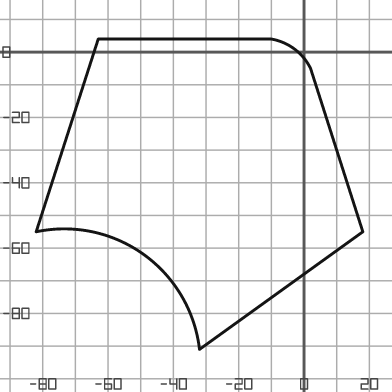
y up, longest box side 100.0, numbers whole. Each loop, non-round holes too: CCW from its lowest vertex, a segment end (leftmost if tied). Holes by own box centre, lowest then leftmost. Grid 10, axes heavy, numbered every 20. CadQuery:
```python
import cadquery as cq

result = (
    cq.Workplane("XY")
    .moveTo(-32.0, -91.0)
    .lineTo(18.0, -55.0)
    .lineTo(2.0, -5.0)
    .threePointArc((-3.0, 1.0), (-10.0, 4.0))
    .lineTo(-63.0, 4.0)
    .lineTo(-82.0, -55.0)
    .threePointArc((-49.0, -62.0), (-32.0, -91.0))
    .close()
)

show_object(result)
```